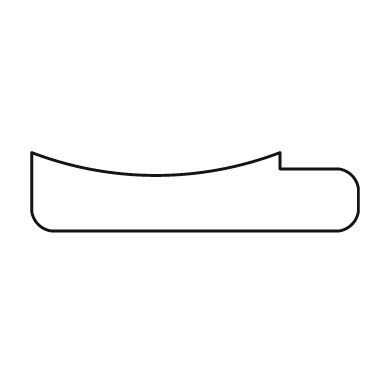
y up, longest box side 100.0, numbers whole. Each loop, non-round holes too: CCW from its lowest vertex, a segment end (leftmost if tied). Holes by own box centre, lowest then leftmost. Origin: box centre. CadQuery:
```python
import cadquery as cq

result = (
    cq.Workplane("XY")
    .moveTo(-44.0, -12.0)
    .lineTo(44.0, -12.0)
    .threePointArc((48.0, -10.0), (50.0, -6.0))
    .lineTo(50.0, 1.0)
    .threePointArc((48.0, 5.0), (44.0, 7.0))
    .lineTo(26.0, 7.0)
    .lineTo(26.0, 12.0)
    .threePointArc((-12.0, 5.0), (-50.0, 12.0))
    .lineTo(-50.0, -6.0)
    .threePointArc((-48.0, -10.0), (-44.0, -12.0))
    .close()
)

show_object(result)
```